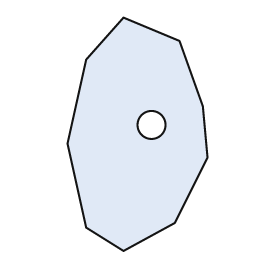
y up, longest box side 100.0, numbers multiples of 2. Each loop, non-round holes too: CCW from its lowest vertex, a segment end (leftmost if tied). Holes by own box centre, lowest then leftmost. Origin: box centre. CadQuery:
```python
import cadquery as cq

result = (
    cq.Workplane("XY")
    .moveTo(-6.0, -50.0)
    .lineTo(16.0, -38.0)
    .lineTo(30.0, -10.0)
    .lineTo(28.0, 12.0)
    .lineTo(18.0, 40.0)
    .lineTo(-6.0, 50.0)
    .lineTo(-22.0, 32.0)
    .lineTo(-30.0, -4.0)
    .lineTo(-22.0, -40.0)
    .close()
    .moveTo(6.0, 4.0)
    .circle(6.0)
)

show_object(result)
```